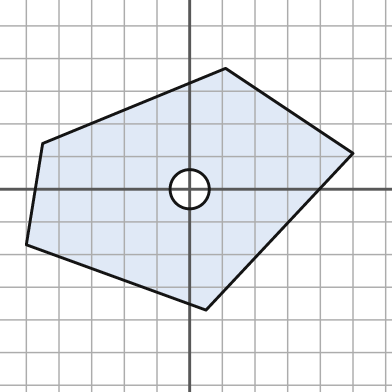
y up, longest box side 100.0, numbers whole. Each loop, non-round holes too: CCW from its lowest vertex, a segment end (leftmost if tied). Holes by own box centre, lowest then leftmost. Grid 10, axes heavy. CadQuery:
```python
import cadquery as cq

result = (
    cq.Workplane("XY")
    .moveTo(5.0, -37.0)
    .lineTo(50.0, 11.0)
    .lineTo(11.0, 37.0)
    .lineTo(-45.0, 14.0)
    .lineTo(-50.0, -17.0)
    .close()
    .moveTo(0.0, 0.0)
    .circle(6.0)
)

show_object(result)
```